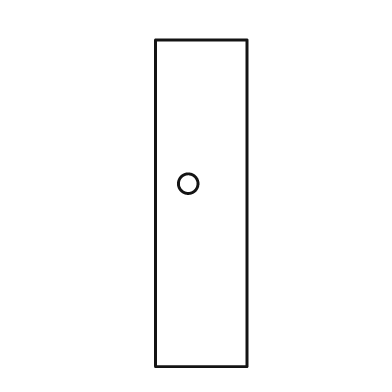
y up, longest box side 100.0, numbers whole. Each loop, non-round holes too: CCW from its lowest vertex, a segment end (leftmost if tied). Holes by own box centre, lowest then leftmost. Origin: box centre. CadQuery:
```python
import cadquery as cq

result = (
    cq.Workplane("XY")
    .moveTo(-14.0, -50.0)
    .lineTo(14.0, -50.0)
    .lineTo(14.0, 50.0)
    .lineTo(-14.0, 50.0)
    .close()
    .moveTo(-4.0, 6.0)
    .circle(3.0)
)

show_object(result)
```